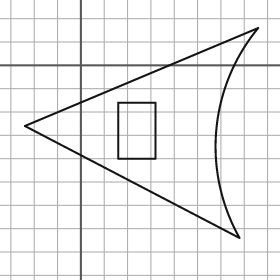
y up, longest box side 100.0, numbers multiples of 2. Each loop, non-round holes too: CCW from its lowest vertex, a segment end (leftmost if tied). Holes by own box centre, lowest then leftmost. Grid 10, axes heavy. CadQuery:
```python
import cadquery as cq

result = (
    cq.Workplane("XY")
    .moveTo(68.0, -74.0)
    .threePointArc((58.0, -28.0), (76.0, 16.0))
    .lineTo(-24.0, -26.0)
    .close()
    .moveTo(16.0, -40.0)
    .lineTo(32.0, -40.0)
    .lineTo(32.0, -16.0)
    .lineTo(16.0, -16.0)
    .close()
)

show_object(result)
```